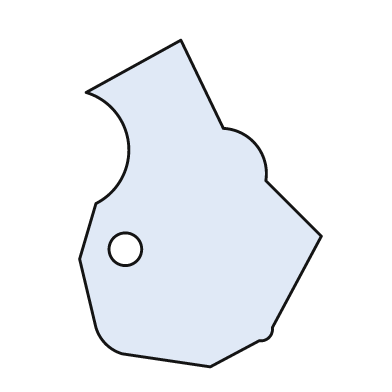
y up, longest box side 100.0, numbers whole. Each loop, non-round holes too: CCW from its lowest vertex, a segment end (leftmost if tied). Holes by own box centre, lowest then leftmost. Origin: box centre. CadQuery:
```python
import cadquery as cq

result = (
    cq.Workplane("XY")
    .moveTo(3.0, -50.0)
    .lineTo(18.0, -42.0)
    .threePointArc((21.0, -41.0), (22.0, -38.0))
    .lineTo(37.0, -10.0)
    .lineTo(20.0, 7.0)
    .threePointArc((17.0, 18.0), (7.0, 23.0))
    .lineTo(-6.0, 50.0)
    .lineTo(-35.0, 34.0)
    .threePointArc((-22.0, 18.0), (-32.0, 0.0))
    .lineTo(-37.0, -17.0)
    .lineTo(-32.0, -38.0)
    .threePointArc((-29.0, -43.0), (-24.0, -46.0))
    .close()
    .moveTo(-23.0, -14.0)
    .circle(5.0)
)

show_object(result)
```